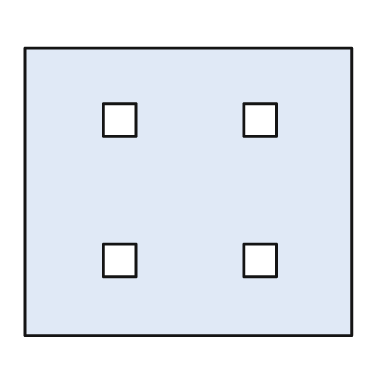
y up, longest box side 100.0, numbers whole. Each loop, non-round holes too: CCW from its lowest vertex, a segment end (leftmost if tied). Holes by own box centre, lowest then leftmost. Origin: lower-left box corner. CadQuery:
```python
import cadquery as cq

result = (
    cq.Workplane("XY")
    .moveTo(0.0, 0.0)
    .lineTo(100.0, 0.0)
    .lineTo(100.0, 88.0)
    .lineTo(0.0, 88.0)
    .close()
    .moveTo(24.0, 18.0)
    .lineTo(34.0, 18.0)
    .lineTo(34.0, 28.0)
    .lineTo(24.0, 28.0)
    .close()
    .moveTo(67.0, 18.0)
    .lineTo(77.0, 18.0)
    .lineTo(77.0, 28.0)
    .lineTo(67.0, 28.0)
    .close()
    .moveTo(24.0, 61.0)
    .lineTo(34.0, 61.0)
    .lineTo(34.0, 71.0)
    .lineTo(24.0, 71.0)
    .close()
    .moveTo(67.0, 61.0)
    .lineTo(77.0, 61.0)
    .lineTo(77.0, 71.0)
    .lineTo(67.0, 71.0)
    .close()
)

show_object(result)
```